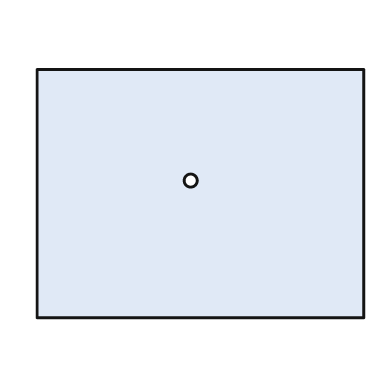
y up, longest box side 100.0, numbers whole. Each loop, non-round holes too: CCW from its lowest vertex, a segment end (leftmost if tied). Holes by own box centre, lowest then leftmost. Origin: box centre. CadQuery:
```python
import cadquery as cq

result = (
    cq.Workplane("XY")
    .moveTo(-50.0, -38.0)
    .lineTo(50.0, -38.0)
    .lineTo(50.0, 38.0)
    .lineTo(-50.0, 38.0)
    .close()
    .moveTo(-3.0, 4.0)
    .circle(2.0)
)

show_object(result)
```